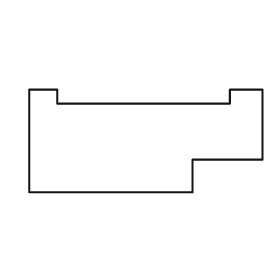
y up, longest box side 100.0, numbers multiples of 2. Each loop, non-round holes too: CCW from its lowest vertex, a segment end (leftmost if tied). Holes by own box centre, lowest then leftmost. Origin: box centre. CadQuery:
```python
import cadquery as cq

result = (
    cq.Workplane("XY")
    .moveTo(-50.0, -22.0)
    .lineTo(20.0, -22.0)
    .lineTo(20.0, -8.0)
    .lineTo(50.0, -8.0)
    .lineTo(50.0, 22.0)
    .lineTo(36.0, 22.0)
    .lineTo(36.0, 16.0)
    .lineTo(-38.0, 16.0)
    .lineTo(-38.0, 22.0)
    .lineTo(-50.0, 22.0)
    .close()
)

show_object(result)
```